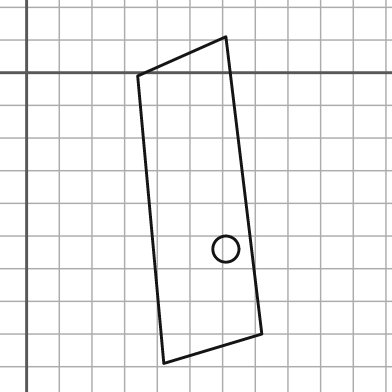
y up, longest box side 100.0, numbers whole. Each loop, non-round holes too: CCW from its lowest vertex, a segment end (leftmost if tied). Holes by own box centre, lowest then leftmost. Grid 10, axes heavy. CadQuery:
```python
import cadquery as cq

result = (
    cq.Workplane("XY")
    .moveTo(42.0, -89.0)
    .lineTo(72.0, -80.0)
    .lineTo(61.0, 11.0)
    .lineTo(34.0, -1.0)
    .close()
    .moveTo(61.0, -54.0)
    .circle(4.0)
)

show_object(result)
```